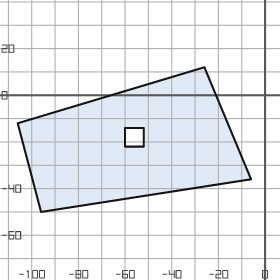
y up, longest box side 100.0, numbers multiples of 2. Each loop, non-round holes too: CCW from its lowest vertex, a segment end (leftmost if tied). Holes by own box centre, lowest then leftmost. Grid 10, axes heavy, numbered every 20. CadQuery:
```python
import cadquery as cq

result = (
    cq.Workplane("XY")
    .moveTo(-96.0, -50.0)
    .lineTo(-6.0, -36.0)
    .lineTo(-26.0, 12.0)
    .lineTo(-106.0, -12.0)
    .close()
    .moveTo(-60.0, -22.0)
    .lineTo(-52.0, -22.0)
    .lineTo(-52.0, -14.0)
    .lineTo(-60.0, -14.0)
    .close()
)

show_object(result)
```